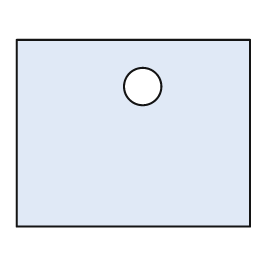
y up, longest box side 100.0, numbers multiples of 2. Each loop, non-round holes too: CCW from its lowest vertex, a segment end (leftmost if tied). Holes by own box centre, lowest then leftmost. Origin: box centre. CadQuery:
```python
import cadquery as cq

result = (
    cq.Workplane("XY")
    .moveTo(-50.0, -40.0)
    .lineTo(50.0, -40.0)
    .lineTo(50.0, 40.0)
    .lineTo(-50.0, 40.0)
    .close()
    .moveTo(4.0, 20.0)
    .circle(8.0)
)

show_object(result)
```